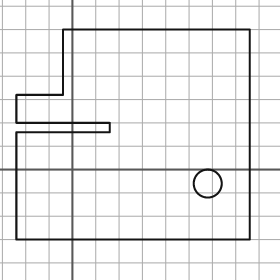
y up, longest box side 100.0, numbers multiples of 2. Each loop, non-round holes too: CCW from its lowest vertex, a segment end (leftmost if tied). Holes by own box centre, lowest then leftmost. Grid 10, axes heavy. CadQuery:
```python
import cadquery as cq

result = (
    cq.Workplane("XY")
    .moveTo(-24.0, -30.0)
    .lineTo(76.0, -30.0)
    .lineTo(76.0, 60.0)
    .lineTo(-4.0, 60.0)
    .lineTo(-4.0, 32.0)
    .lineTo(-24.0, 32.0)
    .lineTo(-24.0, 20.0)
    .lineTo(16.0, 20.0)
    .lineTo(16.0, 16.0)
    .lineTo(-24.0, 16.0)
    .close()
    .moveTo(58.0, -6.0)
    .circle(6.0)
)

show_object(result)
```